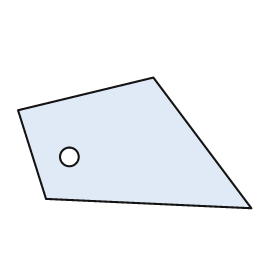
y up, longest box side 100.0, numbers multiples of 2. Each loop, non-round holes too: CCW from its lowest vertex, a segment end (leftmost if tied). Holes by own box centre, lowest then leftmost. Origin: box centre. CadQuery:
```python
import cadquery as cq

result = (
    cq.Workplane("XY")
    .moveTo(50.0, -28.0)
    .lineTo(8.0, 28.0)
    .lineTo(-50.0, 14.0)
    .lineTo(-38.0, -24.0)
    .close()
    .moveTo(-28.0, -6.0)
    .circle(4.0)
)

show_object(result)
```